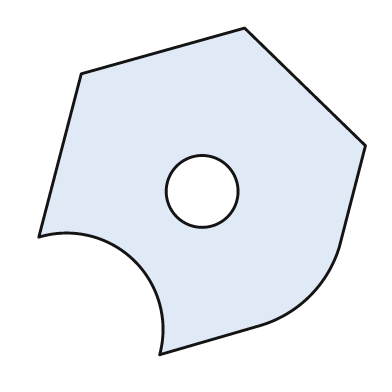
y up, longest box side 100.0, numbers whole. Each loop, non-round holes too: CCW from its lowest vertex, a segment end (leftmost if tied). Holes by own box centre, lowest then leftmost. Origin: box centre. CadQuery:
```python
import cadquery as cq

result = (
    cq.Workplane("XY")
    .moveTo(-13.0, -50.0)
    .lineTo(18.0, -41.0)
    .threePointArc((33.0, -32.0), (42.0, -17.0))
    .lineTo(50.0, 14.0)
    .lineTo(13.0, 50.0)
    .lineTo(-37.0, 36.0)
    .lineTo(-50.0, -14.0)
    .threePointArc((-21.0, -21.0), (-13.0, -50.0))
    .close()
    .moveTo(0.0, 0.0)
    .circle(11.0)
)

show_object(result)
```